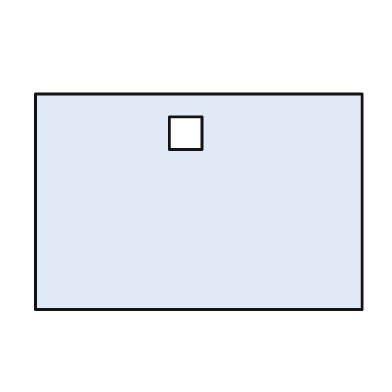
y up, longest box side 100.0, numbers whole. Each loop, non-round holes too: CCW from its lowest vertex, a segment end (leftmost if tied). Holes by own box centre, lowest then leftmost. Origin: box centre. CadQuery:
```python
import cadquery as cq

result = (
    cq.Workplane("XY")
    .moveTo(-50.0, -33.0)
    .lineTo(50.0, -33.0)
    .lineTo(50.0, 33.0)
    .lineTo(-50.0, 33.0)
    .close()
    .moveTo(-9.0, 16.0)
    .lineTo(1.0, 16.0)
    .lineTo(1.0, 26.0)
    .lineTo(-9.0, 26.0)
    .close()
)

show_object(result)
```